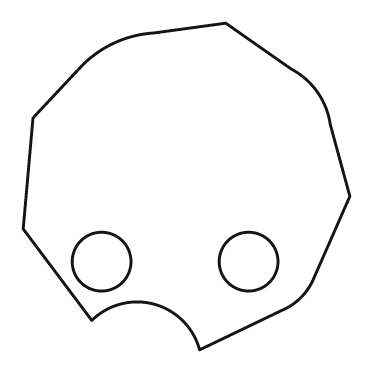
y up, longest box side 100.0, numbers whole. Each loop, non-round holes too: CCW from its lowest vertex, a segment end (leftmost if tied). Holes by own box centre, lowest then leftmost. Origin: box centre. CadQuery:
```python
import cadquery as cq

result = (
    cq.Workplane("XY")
    .moveTo(4.0, -50.0)
    .lineTo(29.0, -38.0)
    .threePointArc((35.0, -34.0), (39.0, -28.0))
    .lineTo(50.0, -3.0)
    .lineTo(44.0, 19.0)
    .threePointArc((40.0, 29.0), (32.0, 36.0))
    .lineTo(12.0, 50.0)
    .lineTo(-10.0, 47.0)
    .threePointArc((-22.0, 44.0), (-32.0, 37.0))
    .lineTo(-47.0, 21.0)
    .lineTo(-50.0, -13.0)
    .lineTo(-29.0, -41.0)
    .threePointArc((-10.0, -36.0), (4.0, -50.0))
    .close()
    .moveTo(-26.0, -23.0)
    .circle(9.0)
    .moveTo(19.0, -23.0)
    .circle(9.0)
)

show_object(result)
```